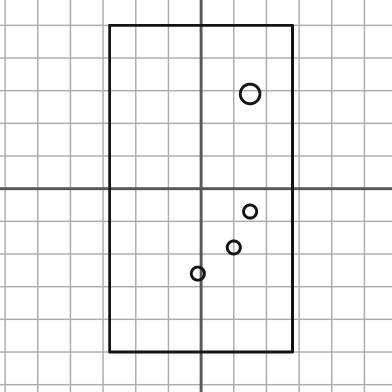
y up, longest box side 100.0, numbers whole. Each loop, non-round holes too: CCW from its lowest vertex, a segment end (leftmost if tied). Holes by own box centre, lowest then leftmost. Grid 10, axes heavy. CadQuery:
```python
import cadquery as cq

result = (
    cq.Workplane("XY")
    .moveTo(-28.0, -50.0)
    .lineTo(28.0, -50.0)
    .lineTo(28.0, 50.0)
    .lineTo(-28.0, 50.0)
    .close()
    .moveTo(-1.0, -26.0)
    .circle(2.0)
    .moveTo(10.0, -18.0)
    .circle(2.0)
    .moveTo(15.0, -7.0)
    .circle(2.0)
    .moveTo(15.0, 29.0)
    .circle(3.0)
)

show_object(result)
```